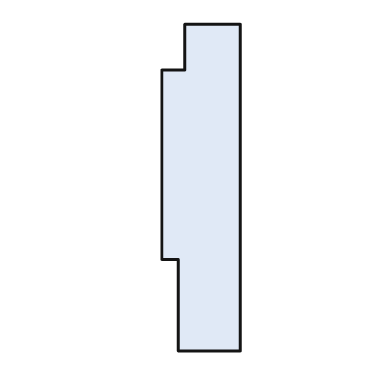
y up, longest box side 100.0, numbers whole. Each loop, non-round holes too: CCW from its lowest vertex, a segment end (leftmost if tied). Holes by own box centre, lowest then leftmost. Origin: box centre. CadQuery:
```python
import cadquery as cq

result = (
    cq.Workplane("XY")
    .moveTo(-7.0, -50.0)
    .lineTo(12.0, -50.0)
    .lineTo(12.0, 50.0)
    .lineTo(-5.0, 50.0)
    .lineTo(-5.0, 36.0)
    .lineTo(-12.0, 36.0)
    .lineTo(-12.0, -22.0)
    .lineTo(-7.0, -22.0)
    .close()
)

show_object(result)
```